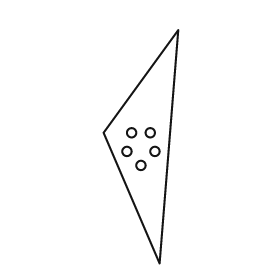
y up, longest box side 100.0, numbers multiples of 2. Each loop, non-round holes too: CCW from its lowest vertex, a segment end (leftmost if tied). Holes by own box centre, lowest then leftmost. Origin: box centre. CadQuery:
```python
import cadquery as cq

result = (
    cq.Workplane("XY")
    .moveTo(8.0, -50.0)
    .lineTo(16.0, 50.0)
    .lineTo(-16.0, 6.0)
    .close()
    .moveTo(0.0, -8.0)
    .circle(2.0)
    .moveTo(-6.0, -2.0)
    .circle(2.0)
    .moveTo(6.0, -2.0)
    .circle(2.0)
    .moveTo(-4.0, 6.0)
    .circle(2.0)
    .moveTo(4.0, 6.0)
    .circle(2.0)
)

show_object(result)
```